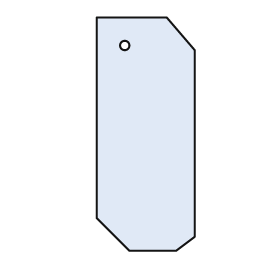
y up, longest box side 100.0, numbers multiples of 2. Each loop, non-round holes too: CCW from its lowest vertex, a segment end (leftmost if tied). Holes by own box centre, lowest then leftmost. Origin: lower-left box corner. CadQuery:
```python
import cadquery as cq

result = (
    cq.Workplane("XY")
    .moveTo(14.0, 0.0)
    .lineTo(34.0, 0.0)
    .lineTo(42.0, 6.0)
    .lineTo(42.0, 86.0)
    .lineTo(30.0, 100.0)
    .lineTo(0.0, 100.0)
    .lineTo(0.0, 14.0)
    .close()
    .moveTo(12.0, 88.0)
    .circle(2.0)
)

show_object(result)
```